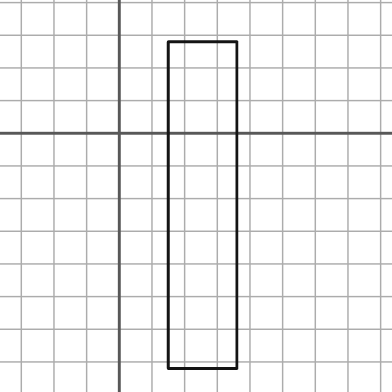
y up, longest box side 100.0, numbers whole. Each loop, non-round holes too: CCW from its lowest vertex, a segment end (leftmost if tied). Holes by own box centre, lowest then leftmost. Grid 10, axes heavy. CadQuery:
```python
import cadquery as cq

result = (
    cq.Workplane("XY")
    .moveTo(15.0, -72.0)
    .lineTo(36.0, -72.0)
    .lineTo(36.0, 28.0)
    .lineTo(15.0, 28.0)
    .close()
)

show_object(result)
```